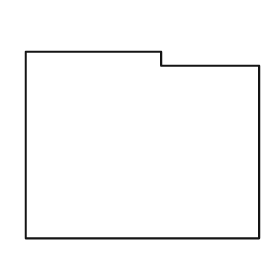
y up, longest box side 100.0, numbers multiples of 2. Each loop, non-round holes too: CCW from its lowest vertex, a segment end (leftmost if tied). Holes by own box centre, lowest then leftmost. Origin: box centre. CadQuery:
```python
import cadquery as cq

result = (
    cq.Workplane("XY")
    .moveTo(-50.0, -40.0)
    .lineTo(50.0, -40.0)
    .lineTo(50.0, 34.0)
    .lineTo(8.0, 34.0)
    .lineTo(8.0, 40.0)
    .lineTo(-50.0, 40.0)
    .close()
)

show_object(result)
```